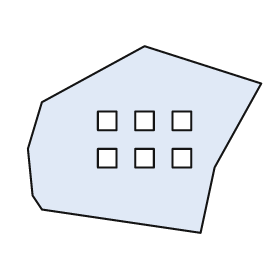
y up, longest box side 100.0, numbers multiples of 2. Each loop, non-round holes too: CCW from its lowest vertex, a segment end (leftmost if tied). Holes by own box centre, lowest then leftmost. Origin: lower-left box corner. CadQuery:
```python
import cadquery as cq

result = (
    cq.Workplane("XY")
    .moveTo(74.0, 0.0)
    .lineTo(80.0, 28.0)
    .lineTo(100.0, 64.0)
    .lineTo(50.0, 80.0)
    .lineTo(6.0, 56.0)
    .lineTo(0.0, 36.0)
    .lineTo(2.0, 16.0)
    .lineTo(6.0, 10.0)
    .close()
    .moveTo(30.0, 28.0)
    .lineTo(38.0, 28.0)
    .lineTo(38.0, 36.0)
    .lineTo(30.0, 36.0)
    .close()
    .moveTo(46.0, 28.0)
    .lineTo(54.0, 28.0)
    .lineTo(54.0, 36.0)
    .lineTo(46.0, 36.0)
    .close()
    .moveTo(62.0, 28.0)
    .lineTo(70.0, 28.0)
    .lineTo(70.0, 36.0)
    .lineTo(62.0, 36.0)
    .close()
    .moveTo(30.0, 44.0)
    .lineTo(38.0, 44.0)
    .lineTo(38.0, 52.0)
    .lineTo(30.0, 52.0)
    .close()
    .moveTo(46.0, 44.0)
    .lineTo(54.0, 44.0)
    .lineTo(54.0, 52.0)
    .lineTo(46.0, 52.0)
    .close()
    .moveTo(62.0, 44.0)
    .lineTo(70.0, 44.0)
    .lineTo(70.0, 52.0)
    .lineTo(62.0, 52.0)
    .close()
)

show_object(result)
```